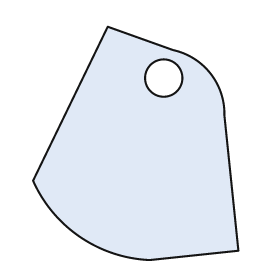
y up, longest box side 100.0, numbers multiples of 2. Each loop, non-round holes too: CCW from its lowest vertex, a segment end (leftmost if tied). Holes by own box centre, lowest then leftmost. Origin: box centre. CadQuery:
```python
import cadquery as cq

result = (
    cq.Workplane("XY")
    .moveTo(6.0, -50.0)
    .lineTo(44.0, -46.0)
    .lineTo(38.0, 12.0)
    .threePointArc((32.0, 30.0), (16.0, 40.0))
    .lineTo(-12.0, 50.0)
    .lineTo(-44.0, -16.0)
    .threePointArc((-24.0, -40.0), (6.0, -50.0))
    .close()
    .moveTo(12.0, 28.0)
    .circle(8.0)
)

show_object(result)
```